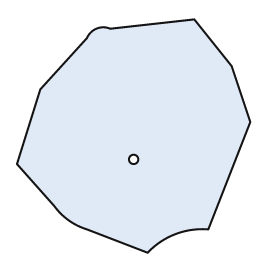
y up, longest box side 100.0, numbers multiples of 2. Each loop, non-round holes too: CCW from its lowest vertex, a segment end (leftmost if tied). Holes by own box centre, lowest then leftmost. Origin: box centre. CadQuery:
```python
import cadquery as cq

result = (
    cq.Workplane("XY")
    .moveTo(6.0, -50.0)
    .threePointArc((18.0, -42.0), (32.0, -40.0))
    .lineTo(50.0, 6.0)
    .lineTo(42.0, 30.0)
    .lineTo(26.0, 50.0)
    .lineTo(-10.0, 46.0)
    .threePointArc((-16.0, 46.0), (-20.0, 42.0))
    .lineTo(-40.0, 20.0)
    .lineTo(-50.0, -12.0)
    .lineTo(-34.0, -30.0)
    .threePointArc((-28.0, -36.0), (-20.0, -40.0))
    .close()
    .moveTo(0.0, -10.0)
    .circle(2.0)
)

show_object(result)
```